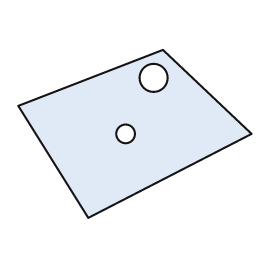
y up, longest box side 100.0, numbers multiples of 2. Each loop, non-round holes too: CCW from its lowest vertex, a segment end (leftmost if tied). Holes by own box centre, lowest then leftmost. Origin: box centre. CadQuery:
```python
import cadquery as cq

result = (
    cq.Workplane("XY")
    .moveTo(-20.0, -36.0)
    .lineTo(50.0, 0.0)
    .lineTo(12.0, 36.0)
    .lineTo(-50.0, 12.0)
    .close()
    .moveTo(-4.0, 0.0)
    .circle(4.0)
    .moveTo(8.0, 24.0)
    .circle(6.0)
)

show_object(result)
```